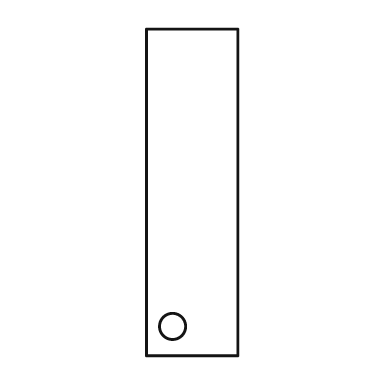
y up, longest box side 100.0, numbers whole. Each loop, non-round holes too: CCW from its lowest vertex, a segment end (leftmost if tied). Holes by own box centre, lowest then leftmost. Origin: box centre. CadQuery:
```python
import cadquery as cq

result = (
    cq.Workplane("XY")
    .moveTo(-14.0, -50.0)
    .lineTo(14.0, -50.0)
    .lineTo(14.0, 50.0)
    .lineTo(-14.0, 50.0)
    .close()
    .moveTo(-6.0, -41.0)
    .circle(4.0)
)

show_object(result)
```